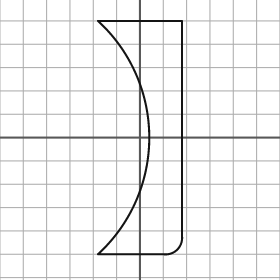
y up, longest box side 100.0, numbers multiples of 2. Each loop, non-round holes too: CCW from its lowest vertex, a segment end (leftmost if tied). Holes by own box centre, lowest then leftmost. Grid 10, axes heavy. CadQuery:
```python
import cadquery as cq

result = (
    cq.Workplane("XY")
    .moveTo(-18.0, -50.0)
    .lineTo(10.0, -50.0)
    .threePointArc((16.0, -48.0), (18.0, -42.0))
    .lineTo(18.0, 50.0)
    .lineTo(-18.0, 50.0)
    .threePointArc((4.0, 0.0), (-18.0, -50.0))
    .close()
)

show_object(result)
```